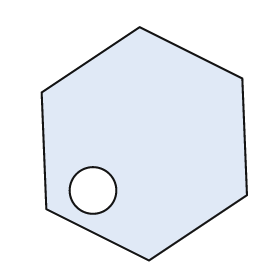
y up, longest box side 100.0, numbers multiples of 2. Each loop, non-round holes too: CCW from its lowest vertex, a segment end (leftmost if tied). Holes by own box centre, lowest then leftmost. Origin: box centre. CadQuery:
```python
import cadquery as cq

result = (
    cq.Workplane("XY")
    .moveTo(2.0, -50.0)
    .lineTo(44.0, -22.0)
    .lineTo(42.0, 28.0)
    .lineTo(-2.0, 50.0)
    .lineTo(-44.0, 22.0)
    .lineTo(-42.0, -28.0)
    .close()
    .moveTo(-22.0, -20.0)
    .circle(10.0)
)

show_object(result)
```